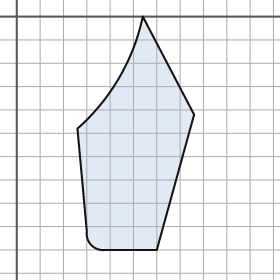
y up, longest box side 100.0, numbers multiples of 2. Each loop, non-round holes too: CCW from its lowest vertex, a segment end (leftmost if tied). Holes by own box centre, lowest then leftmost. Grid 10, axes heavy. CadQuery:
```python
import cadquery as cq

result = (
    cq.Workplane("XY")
    .moveTo(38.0, -100.0)
    .lineTo(60.0, -100.0)
    .lineTo(76.0, -42.0)
    .lineTo(54.0, 0.0)
    .threePointArc((44.0, -26.0), (26.0, -48.0))
    .lineTo(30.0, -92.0)
    .threePointArc((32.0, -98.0), (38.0, -100.0))
    .close()
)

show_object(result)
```